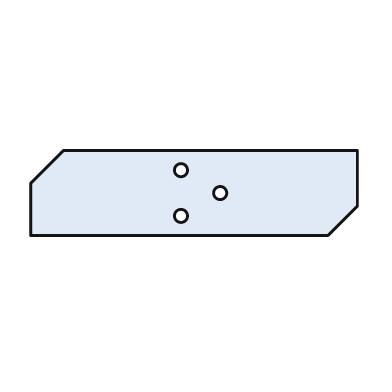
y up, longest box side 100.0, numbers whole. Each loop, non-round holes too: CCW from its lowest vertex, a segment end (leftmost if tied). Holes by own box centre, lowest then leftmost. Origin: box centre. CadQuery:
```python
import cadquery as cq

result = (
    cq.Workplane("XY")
    .moveTo(-50.0, -13.0)
    .lineTo(41.0, -13.0)
    .lineTo(50.0, -4.0)
    .lineTo(50.0, 13.0)
    .lineTo(-40.0, 13.0)
    .lineTo(-50.0, 3.0)
    .close()
    .moveTo(-4.0, -7.0)
    .circle(2.0)
    .moveTo(8.0, 0.0)
    .circle(2.0)
    .moveTo(-4.0, 7.0)
    .circle(2.0)
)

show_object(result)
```